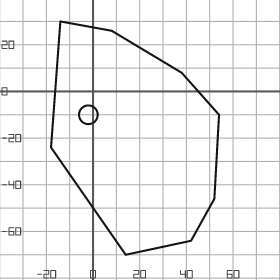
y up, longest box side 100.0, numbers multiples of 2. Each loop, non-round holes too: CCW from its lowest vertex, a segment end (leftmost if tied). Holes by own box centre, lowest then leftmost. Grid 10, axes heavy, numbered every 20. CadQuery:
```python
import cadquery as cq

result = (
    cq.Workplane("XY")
    .moveTo(14.0, -70.0)
    .lineTo(42.0, -64.0)
    .lineTo(52.0, -46.0)
    .lineTo(54.0, -10.0)
    .lineTo(38.0, 8.0)
    .lineTo(8.0, 26.0)
    .lineTo(-14.0, 30.0)
    .lineTo(-18.0, -24.0)
    .close()
    .moveTo(-2.0, -10.0)
    .circle(4.0)
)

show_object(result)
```